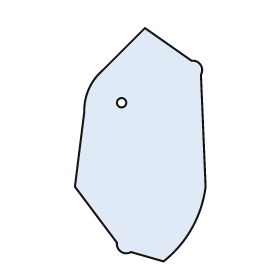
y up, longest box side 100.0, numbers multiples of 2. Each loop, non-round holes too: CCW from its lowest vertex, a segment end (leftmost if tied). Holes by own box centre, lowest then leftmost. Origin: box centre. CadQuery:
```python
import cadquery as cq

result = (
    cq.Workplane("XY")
    .moveTo(10.0, -50.0)
    .threePointArc((22.0, -36.0), (28.0, -18.0))
    .lineTo(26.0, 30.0)
    .threePointArc((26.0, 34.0), (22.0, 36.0))
    .lineTo(2.0, 50.0)
    .lineTo(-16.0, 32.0)
    .threePointArc((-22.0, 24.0), (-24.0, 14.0))
    .lineTo(-28.0, -18.0)
    .lineTo(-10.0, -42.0)
    .threePointArc((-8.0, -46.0), (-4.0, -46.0))
    .close()
    .moveTo(-8.0, 18.0)
    .circle(2.0)
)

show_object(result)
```